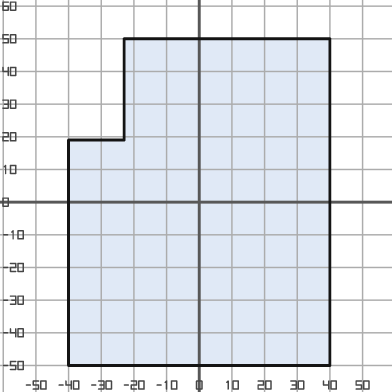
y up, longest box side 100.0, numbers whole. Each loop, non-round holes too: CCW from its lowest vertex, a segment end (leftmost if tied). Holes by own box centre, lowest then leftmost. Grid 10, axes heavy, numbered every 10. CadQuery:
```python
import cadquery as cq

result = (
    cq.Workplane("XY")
    .moveTo(-40.0, -50.0)
    .lineTo(40.0, -50.0)
    .lineTo(40.0, 50.0)
    .lineTo(-23.0, 50.0)
    .lineTo(-23.0, 19.0)
    .lineTo(-40.0, 19.0)
    .close()
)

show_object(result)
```